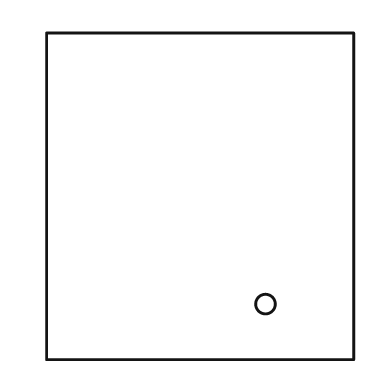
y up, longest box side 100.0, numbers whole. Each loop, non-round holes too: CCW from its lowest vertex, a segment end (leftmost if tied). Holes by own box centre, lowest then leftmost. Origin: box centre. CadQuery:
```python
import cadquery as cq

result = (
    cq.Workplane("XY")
    .moveTo(-47.0, -50.0)
    .lineTo(47.0, -50.0)
    .lineTo(47.0, 50.0)
    .lineTo(-47.0, 50.0)
    .close()
    .moveTo(20.0, -33.0)
    .circle(3.0)
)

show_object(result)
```